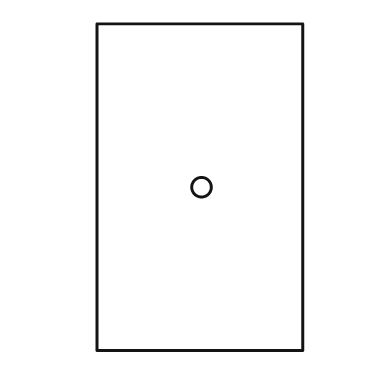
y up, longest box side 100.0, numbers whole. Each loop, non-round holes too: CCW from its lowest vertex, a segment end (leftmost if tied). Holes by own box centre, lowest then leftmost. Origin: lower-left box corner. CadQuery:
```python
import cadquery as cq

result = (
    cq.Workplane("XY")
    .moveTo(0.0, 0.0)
    .lineTo(63.0, 0.0)
    .lineTo(63.0, 100.0)
    .lineTo(0.0, 100.0)
    .close()
    .moveTo(32.0, 50.0)
    .circle(3.0)
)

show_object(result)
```